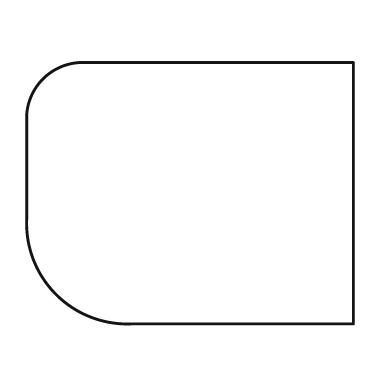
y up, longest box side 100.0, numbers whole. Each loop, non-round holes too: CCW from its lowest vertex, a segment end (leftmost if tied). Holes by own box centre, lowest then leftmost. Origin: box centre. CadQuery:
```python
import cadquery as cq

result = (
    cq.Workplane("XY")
    .moveTo(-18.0, -40.0)
    .lineTo(50.0, -40.0)
    .lineTo(50.0, 40.0)
    .lineTo(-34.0, 40.0)
    .threePointArc((-45.0, 35.0), (-50.0, 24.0))
    .lineTo(-50.0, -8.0)
    .threePointArc((-41.0, -31.0), (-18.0, -40.0))
    .close()
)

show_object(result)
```